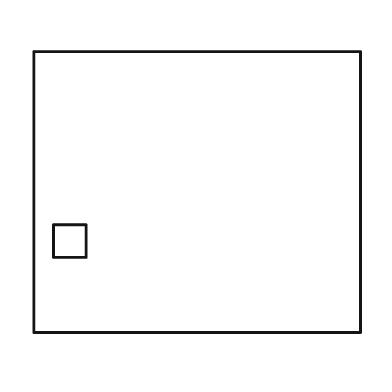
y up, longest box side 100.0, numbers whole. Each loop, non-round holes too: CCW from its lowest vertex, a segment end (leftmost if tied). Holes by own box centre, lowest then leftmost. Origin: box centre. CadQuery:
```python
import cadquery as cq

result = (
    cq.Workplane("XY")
    .moveTo(-50.0, -43.0)
    .lineTo(50.0, -43.0)
    .lineTo(50.0, 43.0)
    .lineTo(-50.0, 43.0)
    .close()
    .moveTo(-44.0, -20.0)
    .lineTo(-34.0, -20.0)
    .lineTo(-34.0, -10.0)
    .lineTo(-44.0, -10.0)
    .close()
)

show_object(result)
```